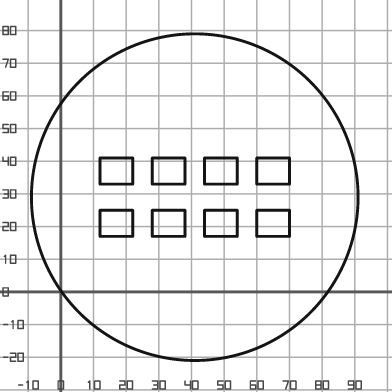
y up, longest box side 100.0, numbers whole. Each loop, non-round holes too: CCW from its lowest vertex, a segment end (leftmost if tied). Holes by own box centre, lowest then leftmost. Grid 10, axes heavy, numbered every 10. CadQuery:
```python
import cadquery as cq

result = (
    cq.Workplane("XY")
    .moveTo(41.0, 29.0)
    .circle(50.0)
    .moveTo(12.0, 17.0)
    .lineTo(22.0, 17.0)
    .lineTo(22.0, 25.0)
    .lineTo(12.0, 25.0)
    .close()
    .moveTo(28.0, 17.0)
    .lineTo(38.0, 17.0)
    .lineTo(38.0, 25.0)
    .lineTo(28.0, 25.0)
    .close()
    .moveTo(44.0, 17.0)
    .lineTo(54.0, 17.0)
    .lineTo(54.0, 25.0)
    .lineTo(44.0, 25.0)
    .close()
    .moveTo(60.0, 17.0)
    .lineTo(70.0, 17.0)
    .lineTo(70.0, 25.0)
    .lineTo(60.0, 25.0)
    .close()
    .moveTo(12.0, 33.0)
    .lineTo(22.0, 33.0)
    .lineTo(22.0, 41.0)
    .lineTo(12.0, 41.0)
    .close()
    .moveTo(28.0, 33.0)
    .lineTo(38.0, 33.0)
    .lineTo(38.0, 41.0)
    .lineTo(28.0, 41.0)
    .close()
    .moveTo(44.0, 33.0)
    .lineTo(54.0, 33.0)
    .lineTo(54.0, 41.0)
    .lineTo(44.0, 41.0)
    .close()
    .moveTo(60.0, 33.0)
    .lineTo(70.0, 33.0)
    .lineTo(70.0, 41.0)
    .lineTo(60.0, 41.0)
    .close()
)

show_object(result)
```